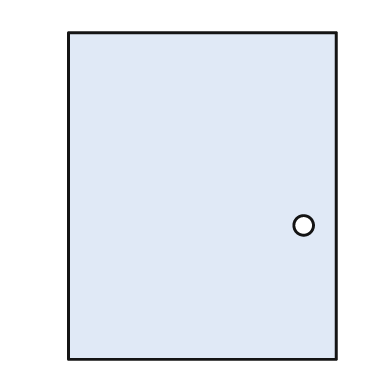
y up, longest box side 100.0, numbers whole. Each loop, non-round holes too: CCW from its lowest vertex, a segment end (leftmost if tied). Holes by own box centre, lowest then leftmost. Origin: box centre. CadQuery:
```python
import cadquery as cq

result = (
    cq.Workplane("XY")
    .moveTo(-41.0, -50.0)
    .lineTo(41.0, -50.0)
    .lineTo(41.0, 50.0)
    .lineTo(-41.0, 50.0)
    .close()
    .moveTo(31.0, -9.0)
    .circle(3.0)
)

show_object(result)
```